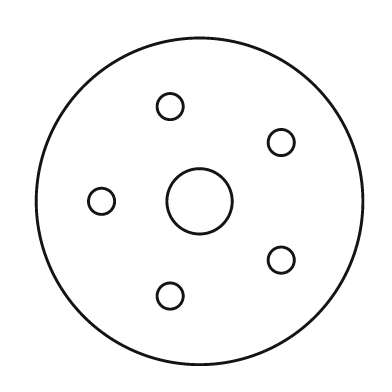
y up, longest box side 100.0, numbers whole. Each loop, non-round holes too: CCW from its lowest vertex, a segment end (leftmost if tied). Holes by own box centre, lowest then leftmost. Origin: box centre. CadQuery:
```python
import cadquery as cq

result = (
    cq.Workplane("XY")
    .moveTo(0.0, 0.0)
    .circle(50.0)
    .moveTo(-9.0, -29.0)
    .circle(4.0)
    .moveTo(25.0, -18.0)
    .circle(4.0)
    .moveTo(-30.0, 0.0)
    .circle(4.0)
    .moveTo(0.0, 0.0)
    .circle(10.0)
    .moveTo(25.0, 18.0)
    .circle(4.0)
    .moveTo(-9.0, 29.0)
    .circle(4.0)
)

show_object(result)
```